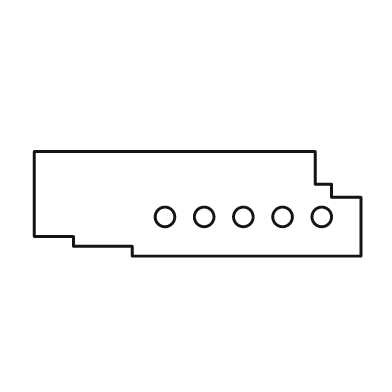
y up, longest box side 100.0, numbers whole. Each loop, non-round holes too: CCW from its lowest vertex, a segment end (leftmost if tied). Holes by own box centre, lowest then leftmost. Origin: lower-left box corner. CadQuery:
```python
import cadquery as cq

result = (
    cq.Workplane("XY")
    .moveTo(30.0, 0.0)
    .lineTo(100.0, 0.0)
    .lineTo(100.0, 18.0)
    .lineTo(91.0, 18.0)
    .lineTo(91.0, 22.0)
    .lineTo(86.0, 22.0)
    .lineTo(86.0, 32.0)
    .lineTo(0.0, 32.0)
    .lineTo(0.0, 6.0)
    .lineTo(12.0, 6.0)
    .lineTo(12.0, 3.0)
    .lineTo(30.0, 3.0)
    .close()
    .moveTo(40.0, 12.0)
    .circle(3.0)
    .moveTo(52.0, 12.0)
    .circle(3.0)
    .moveTo(64.0, 12.0)
    .circle(3.0)
    .moveTo(76.0, 12.0)
    .circle(3.0)
    .moveTo(88.0, 12.0)
    .circle(3.0)
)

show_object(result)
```